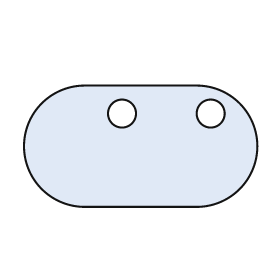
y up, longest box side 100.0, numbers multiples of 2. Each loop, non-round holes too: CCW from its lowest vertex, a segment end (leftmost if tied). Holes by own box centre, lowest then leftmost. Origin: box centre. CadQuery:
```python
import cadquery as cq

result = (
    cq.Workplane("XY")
    .moveTo(-24.0, -26.0)
    .lineTo(24.0, -26.0)
    .threePointArc((50.0, 0.0), (24.0, 26.0))
    .lineTo(-24.0, 26.0)
    .threePointArc((-50.0, 0.0), (-24.0, -26.0))
    .close()
    .moveTo(-8.0, 14.0)
    .circle(6.0)
    .moveTo(30.0, 14.0)
    .circle(6.0)
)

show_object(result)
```